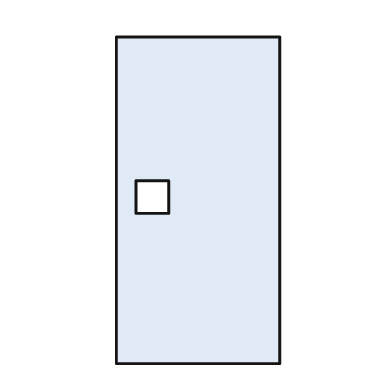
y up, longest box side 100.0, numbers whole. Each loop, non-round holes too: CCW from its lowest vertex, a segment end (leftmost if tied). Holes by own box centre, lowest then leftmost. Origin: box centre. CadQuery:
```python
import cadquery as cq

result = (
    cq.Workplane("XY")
    .moveTo(-25.0, -50.0)
    .lineTo(25.0, -50.0)
    .lineTo(25.0, 50.0)
    .lineTo(-25.0, 50.0)
    .close()
    .moveTo(-19.0, -4.0)
    .lineTo(-9.0, -4.0)
    .lineTo(-9.0, 6.0)
    .lineTo(-19.0, 6.0)
    .close()
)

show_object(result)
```